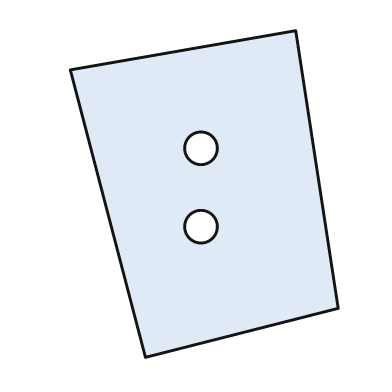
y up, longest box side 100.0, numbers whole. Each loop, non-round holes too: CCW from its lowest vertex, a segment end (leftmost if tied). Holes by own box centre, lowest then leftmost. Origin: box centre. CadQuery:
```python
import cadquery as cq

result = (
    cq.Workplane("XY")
    .moveTo(-18.0, -50.0)
    .lineTo(41.0, -35.0)
    .lineTo(28.0, 50.0)
    .lineTo(-41.0, 38.0)
    .close()
    .moveTo(-1.0, -10.0)
    .circle(5.0)
    .moveTo(-1.0, 14.0)
    .circle(5.0)
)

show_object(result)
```